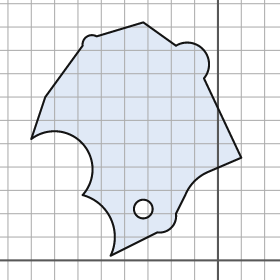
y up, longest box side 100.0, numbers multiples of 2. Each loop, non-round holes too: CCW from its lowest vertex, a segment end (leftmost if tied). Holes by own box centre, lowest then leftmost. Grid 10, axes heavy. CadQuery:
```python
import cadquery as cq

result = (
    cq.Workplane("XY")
    .moveTo(-46.0, 2.0)
    .lineTo(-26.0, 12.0)
    .threePointArc((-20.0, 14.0), (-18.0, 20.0))
    .lineTo(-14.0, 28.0)
    .threePointArc((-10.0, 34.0), (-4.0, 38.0))
    .lineTo(10.0, 44.0)
    .lineTo(-6.0, 78.0)
    .threePointArc((-6.0, 90.0), (-18.0, 92.0))
    .lineTo(-32.0, 102.0)
    .lineTo(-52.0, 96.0)
    .threePointArc((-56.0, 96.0), (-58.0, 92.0))
    .lineTo(-74.0, 70.0)
    .lineTo(-80.0, 52.0)
    .threePointArc((-58.0, 50.0), (-58.0, 28.0))
    .threePointArc((-46.0, 18.0), (-46.0, 2.0))
    .close()
    .moveTo(-32.0, 22.0)
    .circle(4.0)
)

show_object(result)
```